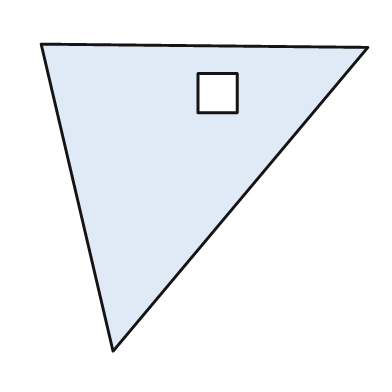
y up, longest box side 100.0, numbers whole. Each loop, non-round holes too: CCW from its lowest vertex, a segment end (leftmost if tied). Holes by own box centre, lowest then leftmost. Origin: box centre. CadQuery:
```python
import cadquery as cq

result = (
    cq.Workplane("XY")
    .moveTo(-28.0, -47.0)
    .lineTo(50.0, 46.0)
    .lineTo(-50.0, 47.0)
    .close()
    .moveTo(-2.0, 26.0)
    .lineTo(10.0, 26.0)
    .lineTo(10.0, 38.0)
    .lineTo(-2.0, 38.0)
    .close()
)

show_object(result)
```